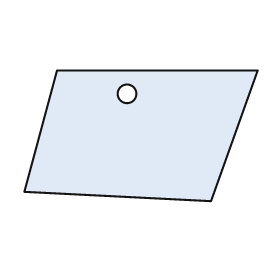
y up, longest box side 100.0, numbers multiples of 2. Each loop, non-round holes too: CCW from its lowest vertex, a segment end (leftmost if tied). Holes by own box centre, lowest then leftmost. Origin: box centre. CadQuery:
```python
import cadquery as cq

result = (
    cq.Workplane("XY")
    .moveTo(30.0, -28.0)
    .lineTo(50.0, 28.0)
    .lineTo(-36.0, 28.0)
    .lineTo(-50.0, -24.0)
    .close()
    .moveTo(-6.0, 18.0)
    .circle(4.0)
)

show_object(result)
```